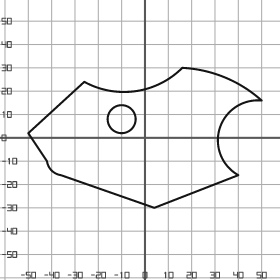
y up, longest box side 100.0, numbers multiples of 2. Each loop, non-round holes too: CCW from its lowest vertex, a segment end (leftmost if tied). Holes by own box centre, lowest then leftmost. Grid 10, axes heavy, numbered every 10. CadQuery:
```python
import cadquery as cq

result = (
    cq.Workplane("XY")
    .moveTo(4.0, -30.0)
    .lineTo(40.0, -16.0)
    .threePointArc((32.0, 4.0), (50.0, 16.0))
    .threePointArc((34.0, 26.0), (16.0, 30.0))
    .threePointArc((-4.0, 20.0), (-26.0, 24.0))
    .lineTo(-50.0, 2.0)
    .lineTo(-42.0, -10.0)
    .threePointArc((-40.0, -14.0), (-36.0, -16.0))
    .close()
    .moveTo(-10.0, 8.0)
    .circle(6.0)
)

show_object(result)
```